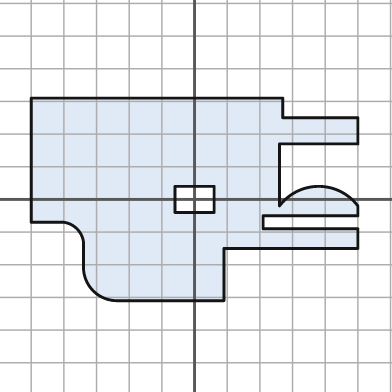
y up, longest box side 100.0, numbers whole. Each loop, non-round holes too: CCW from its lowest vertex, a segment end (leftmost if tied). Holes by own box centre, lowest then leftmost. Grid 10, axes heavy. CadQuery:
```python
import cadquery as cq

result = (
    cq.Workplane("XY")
    .moveTo(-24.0, -31.0)
    .lineTo(9.0, -31.0)
    .lineTo(9.0, -15.0)
    .lineTo(50.0, -15.0)
    .lineTo(50.0, -9.0)
    .lineTo(21.0, -9.0)
    .lineTo(21.0, -5.0)
    .lineTo(50.0, -5.0)
    .lineTo(50.0, -2.0)
    .threePointArc((38.0, 4.0), (26.0, -2.0))
    .lineTo(26.0, 17.0)
    .lineTo(50.0, 17.0)
    .lineTo(50.0, 25.0)
    .lineTo(27.0, 25.0)
    .lineTo(27.0, 31.0)
    .lineTo(-50.0, 31.0)
    .lineTo(-50.0, -7.0)
    .lineTo(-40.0, -7.0)
    .threePointArc((-36.0, -9.0), (-34.0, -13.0))
    .lineTo(-34.0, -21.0)
    .threePointArc((-31.0, -28.0), (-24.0, -31.0))
    .close()
    .moveTo(-6.0, -4.0)
    .lineTo(6.0, -4.0)
    .lineTo(6.0, 4.0)
    .lineTo(-6.0, 4.0)
    .close()
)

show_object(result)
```